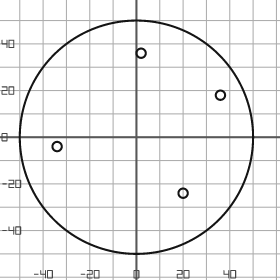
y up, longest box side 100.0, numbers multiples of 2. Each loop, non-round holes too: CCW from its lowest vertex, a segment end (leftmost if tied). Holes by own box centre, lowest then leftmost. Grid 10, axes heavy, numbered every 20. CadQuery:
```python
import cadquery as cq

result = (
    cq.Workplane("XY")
    .moveTo(0.0, 0.0)
    .circle(50.0)
    .moveTo(20.0, -24.0)
    .circle(2.0)
    .moveTo(-34.0, -4.0)
    .circle(2.0)
    .moveTo(36.0, 18.0)
    .circle(2.0)
    .moveTo(2.0, 36.0)
    .circle(2.0)
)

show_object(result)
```